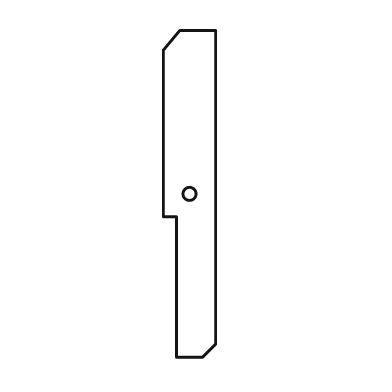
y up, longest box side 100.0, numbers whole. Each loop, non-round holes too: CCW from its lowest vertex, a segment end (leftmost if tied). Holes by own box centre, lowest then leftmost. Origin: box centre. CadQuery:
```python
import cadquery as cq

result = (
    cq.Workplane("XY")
    .moveTo(-4.0, -50.0)
    .lineTo(4.0, -50.0)
    .lineTo(8.0, -46.0)
    .lineTo(8.0, 50.0)
    .lineTo(-3.0, 50.0)
    .lineTo(-8.0, 44.0)
    .lineTo(-8.0, -7.0)
    .lineTo(-4.0, -7.0)
    .close()
    .moveTo(0.0, 0.0)
    .circle(2.0)
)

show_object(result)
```